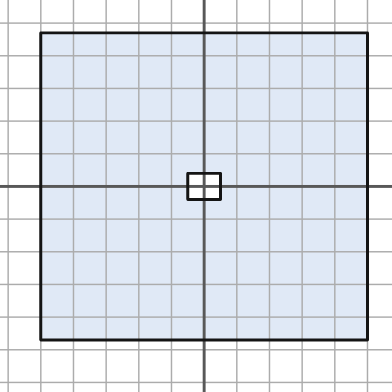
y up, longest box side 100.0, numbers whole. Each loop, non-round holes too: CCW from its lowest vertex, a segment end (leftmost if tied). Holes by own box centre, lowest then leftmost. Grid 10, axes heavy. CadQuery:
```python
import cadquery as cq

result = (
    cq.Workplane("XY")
    .moveTo(-50.0, -47.0)
    .lineTo(50.0, -47.0)
    .lineTo(50.0, 47.0)
    .lineTo(-50.0, 47.0)
    .close()
    .moveTo(-5.0, -4.0)
    .lineTo(5.0, -4.0)
    .lineTo(5.0, 4.0)
    .lineTo(-5.0, 4.0)
    .close()
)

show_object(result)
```